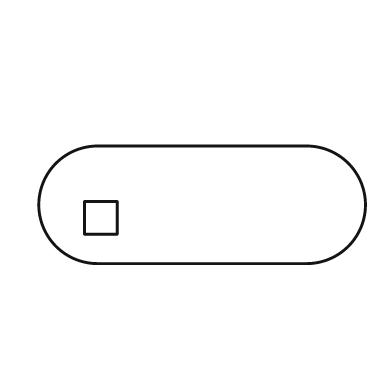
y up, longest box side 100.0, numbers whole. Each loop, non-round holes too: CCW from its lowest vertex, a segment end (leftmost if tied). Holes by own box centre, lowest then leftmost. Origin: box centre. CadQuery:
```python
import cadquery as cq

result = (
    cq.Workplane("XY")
    .moveTo(-32.0, -18.0)
    .lineTo(32.0, -18.0)
    .threePointArc((50.0, 0.0), (32.0, 18.0))
    .lineTo(-32.0, 18.0)
    .threePointArc((-50.0, 0.0), (-32.0, -18.0))
    .close()
    .moveTo(-36.0, -9.0)
    .lineTo(-26.0, -9.0)
    .lineTo(-26.0, 1.0)
    .lineTo(-36.0, 1.0)
    .close()
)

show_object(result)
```